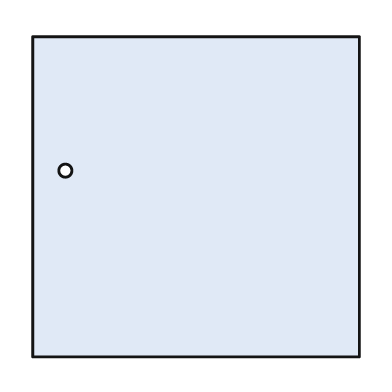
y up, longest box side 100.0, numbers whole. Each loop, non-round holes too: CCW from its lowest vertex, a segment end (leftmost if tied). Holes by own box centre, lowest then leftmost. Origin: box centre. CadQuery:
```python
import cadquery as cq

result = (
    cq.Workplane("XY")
    .moveTo(-50.0, -49.0)
    .lineTo(50.0, -49.0)
    .lineTo(50.0, 49.0)
    .lineTo(-50.0, 49.0)
    .close()
    .moveTo(-40.0, 8.0)
    .circle(2.0)
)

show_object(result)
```